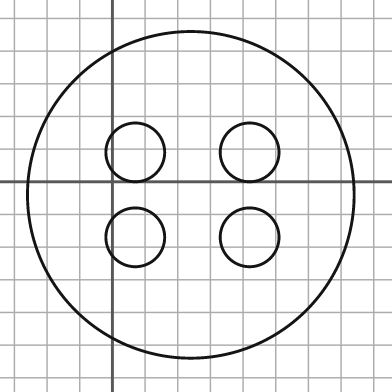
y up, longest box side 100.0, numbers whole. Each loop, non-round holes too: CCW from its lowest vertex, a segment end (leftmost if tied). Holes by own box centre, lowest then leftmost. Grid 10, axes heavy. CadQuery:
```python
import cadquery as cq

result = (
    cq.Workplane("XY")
    .moveTo(24.0, -4.0)
    .circle(50.0)
    .moveTo(7.0, -17.0)
    .circle(9.0)
    .moveTo(42.0, -17.0)
    .circle(9.0)
    .moveTo(7.0, 9.0)
    .circle(9.0)
    .moveTo(42.0, 9.0)
    .circle(9.0)
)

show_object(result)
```